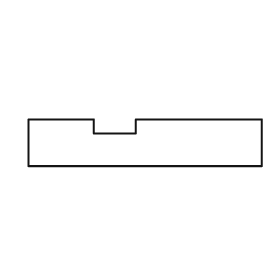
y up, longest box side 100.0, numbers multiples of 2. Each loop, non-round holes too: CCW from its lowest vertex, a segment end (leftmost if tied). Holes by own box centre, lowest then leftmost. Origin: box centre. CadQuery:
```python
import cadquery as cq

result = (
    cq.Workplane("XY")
    .moveTo(-50.0, -10.0)
    .lineTo(50.0, -10.0)
    .lineTo(50.0, 10.0)
    .lineTo(-4.0, 10.0)
    .lineTo(-4.0, 4.0)
    .lineTo(-22.0, 4.0)
    .lineTo(-22.0, 10.0)
    .lineTo(-50.0, 10.0)
    .close()
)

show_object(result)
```